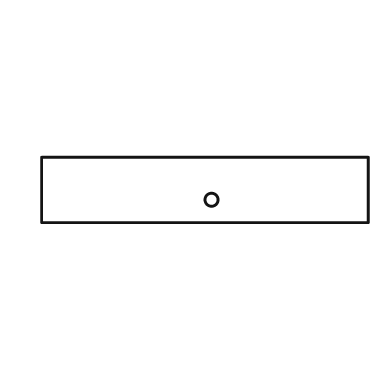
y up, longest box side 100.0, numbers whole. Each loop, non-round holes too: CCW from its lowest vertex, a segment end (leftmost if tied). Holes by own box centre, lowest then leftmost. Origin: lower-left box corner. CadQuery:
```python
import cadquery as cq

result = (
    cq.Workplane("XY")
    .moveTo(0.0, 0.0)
    .lineTo(100.0, 0.0)
    .lineTo(100.0, 20.0)
    .lineTo(0.0, 20.0)
    .close()
    .moveTo(52.0, 7.0)
    .circle(2.0)
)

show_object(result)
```